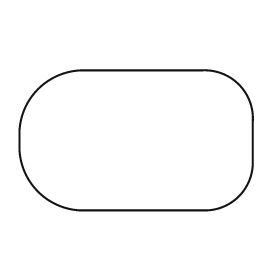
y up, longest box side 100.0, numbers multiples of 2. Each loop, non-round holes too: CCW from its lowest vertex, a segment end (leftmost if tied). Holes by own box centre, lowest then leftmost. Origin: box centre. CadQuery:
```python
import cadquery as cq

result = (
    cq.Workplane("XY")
    .moveTo(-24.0, -30.0)
    .lineTo(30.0, -30.0)
    .threePointArc((44.0, -24.0), (50.0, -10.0))
    .lineTo(50.0, 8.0)
    .threePointArc((44.0, 24.0), (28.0, 30.0))
    .lineTo(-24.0, 30.0)
    .threePointArc((-42.0, 22.0), (-50.0, 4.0))
    .lineTo(-50.0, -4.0)
    .threePointArc((-42.0, -22.0), (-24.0, -30.0))
    .close()
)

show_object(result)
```